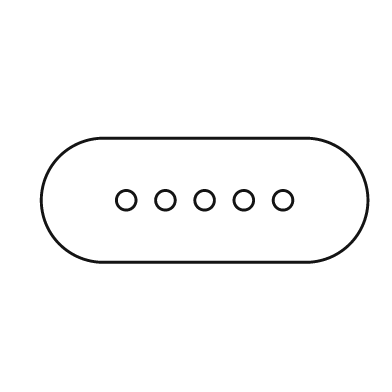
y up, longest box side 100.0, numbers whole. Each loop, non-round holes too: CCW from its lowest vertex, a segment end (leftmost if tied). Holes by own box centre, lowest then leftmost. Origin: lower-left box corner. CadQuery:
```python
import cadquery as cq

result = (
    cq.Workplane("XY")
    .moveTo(19.0, 0.0)
    .lineTo(81.0, 0.0)
    .threePointArc((100.0, 19.0), (81.0, 38.0))
    .lineTo(19.0, 38.0)
    .threePointArc((0.0, 19.0), (19.0, 0.0))
    .close()
    .moveTo(26.0, 19.0)
    .circle(3.0)
    .moveTo(38.0, 19.0)
    .circle(3.0)
    .moveTo(50.0, 19.0)
    .circle(3.0)
    .moveTo(62.0, 19.0)
    .circle(3.0)
    .moveTo(74.0, 19.0)
    .circle(3.0)
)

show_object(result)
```